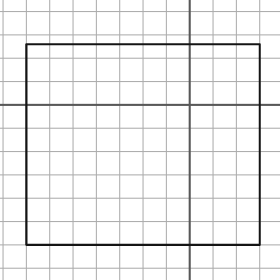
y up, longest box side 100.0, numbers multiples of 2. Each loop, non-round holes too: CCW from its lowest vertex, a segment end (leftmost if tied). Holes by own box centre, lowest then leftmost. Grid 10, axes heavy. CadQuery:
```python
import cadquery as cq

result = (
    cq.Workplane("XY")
    .moveTo(-70.0, -60.0)
    .lineTo(30.0, -60.0)
    .lineTo(30.0, 26.0)
    .lineTo(-70.0, 26.0)
    .close()
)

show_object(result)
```